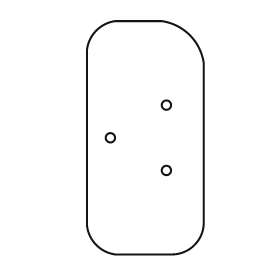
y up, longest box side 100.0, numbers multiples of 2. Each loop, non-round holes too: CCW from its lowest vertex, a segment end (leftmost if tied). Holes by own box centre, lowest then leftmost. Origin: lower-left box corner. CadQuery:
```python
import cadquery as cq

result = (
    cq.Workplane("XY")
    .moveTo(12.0, 0.0)
    .lineTo(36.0, 0.0)
    .threePointArc((46.0, 4.0), (50.0, 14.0))
    .lineTo(50.0, 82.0)
    .threePointArc((44.0, 94.0), (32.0, 100.0))
    .lineTo(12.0, 100.0)
    .threePointArc((4.0, 96.0), (0.0, 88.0))
    .lineTo(0.0, 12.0)
    .threePointArc((4.0, 4.0), (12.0, 0.0))
    .close()
    .moveTo(34.0, 36.0)
    .circle(2.0)
    .moveTo(10.0, 50.0)
    .circle(2.0)
    .moveTo(34.0, 64.0)
    .circle(2.0)
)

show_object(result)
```